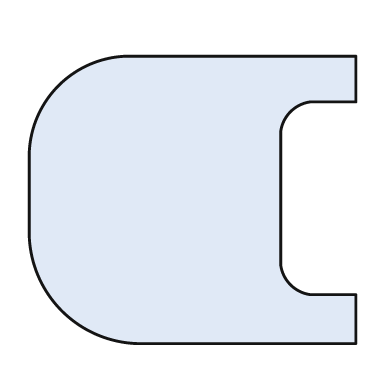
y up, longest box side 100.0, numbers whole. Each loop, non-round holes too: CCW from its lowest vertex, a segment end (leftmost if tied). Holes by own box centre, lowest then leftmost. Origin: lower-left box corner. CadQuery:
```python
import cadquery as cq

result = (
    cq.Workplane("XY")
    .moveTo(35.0, 0.0)
    .lineTo(100.0, 0.0)
    .lineTo(100.0, 15.0)
    .lineTo(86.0, 15.0)
    .threePointArc((80.0, 18.0), (77.0, 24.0))
    .lineTo(77.0, 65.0)
    .threePointArc((80.0, 71.0), (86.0, 74.0))
    .lineTo(100.0, 74.0)
    .lineTo(100.0, 88.0)
    .lineTo(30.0, 88.0)
    .threePointArc((9.0, 79.0), (0.0, 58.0))
    .lineTo(0.0, 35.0)
    .threePointArc((10.0, 10.0), (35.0, 0.0))
    .close()
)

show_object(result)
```